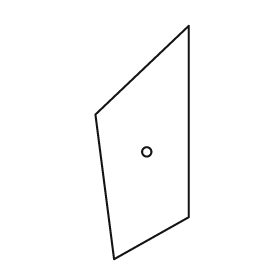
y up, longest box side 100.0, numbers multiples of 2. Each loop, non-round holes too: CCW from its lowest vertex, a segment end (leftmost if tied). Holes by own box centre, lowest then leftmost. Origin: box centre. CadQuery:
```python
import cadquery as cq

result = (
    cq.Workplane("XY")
    .moveTo(-12.0, -50.0)
    .lineTo(20.0, -32.0)
    .lineTo(20.0, 50.0)
    .lineTo(-20.0, 12.0)
    .close()
    .moveTo(2.0, -4.0)
    .circle(2.0)
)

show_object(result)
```